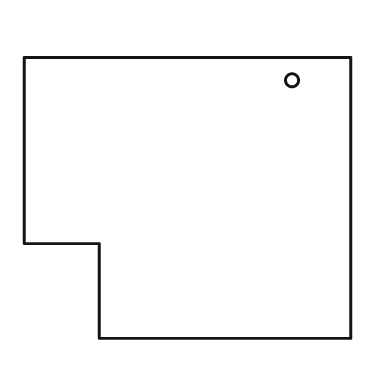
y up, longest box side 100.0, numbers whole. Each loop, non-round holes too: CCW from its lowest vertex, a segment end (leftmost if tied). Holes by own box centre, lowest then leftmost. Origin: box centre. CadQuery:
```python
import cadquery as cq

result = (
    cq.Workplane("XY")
    .moveTo(-27.0, -43.0)
    .lineTo(50.0, -43.0)
    .lineTo(50.0, 43.0)
    .lineTo(-50.0, 43.0)
    .lineTo(-50.0, -14.0)
    .lineTo(-27.0, -14.0)
    .close()
    .moveTo(32.0, 36.0)
    .circle(2.0)
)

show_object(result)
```